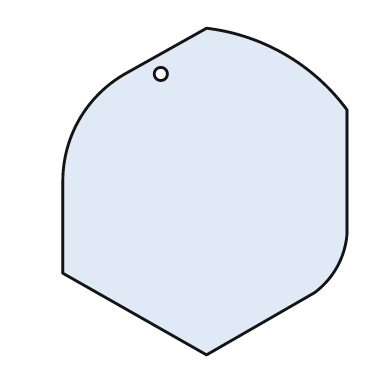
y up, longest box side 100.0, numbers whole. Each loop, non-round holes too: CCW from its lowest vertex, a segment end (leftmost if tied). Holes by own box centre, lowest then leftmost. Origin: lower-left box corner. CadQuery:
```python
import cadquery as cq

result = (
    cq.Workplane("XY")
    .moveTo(44.0, 0.0)
    .lineTo(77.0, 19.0)
    .threePointArc((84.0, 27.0), (87.0, 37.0))
    .lineTo(87.0, 75.0)
    .threePointArc((68.0, 92.0), (44.0, 100.0))
    .lineTo(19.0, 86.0)
    .threePointArc((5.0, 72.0), (0.0, 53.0))
    .lineTo(0.0, 25.0)
    .close()
    .moveTo(30.0, 86.0)
    .circle(2.0)
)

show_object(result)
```